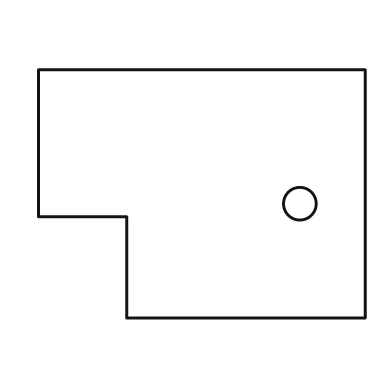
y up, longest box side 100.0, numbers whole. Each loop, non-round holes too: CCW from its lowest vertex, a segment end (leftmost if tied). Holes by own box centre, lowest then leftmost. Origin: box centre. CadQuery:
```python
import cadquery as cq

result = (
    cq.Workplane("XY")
    .moveTo(-23.0, -38.0)
    .lineTo(50.0, -38.0)
    .lineTo(50.0, 38.0)
    .lineTo(-50.0, 38.0)
    .lineTo(-50.0, -7.0)
    .lineTo(-23.0, -7.0)
    .close()
    .moveTo(30.0, -3.0)
    .circle(5.0)
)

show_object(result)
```